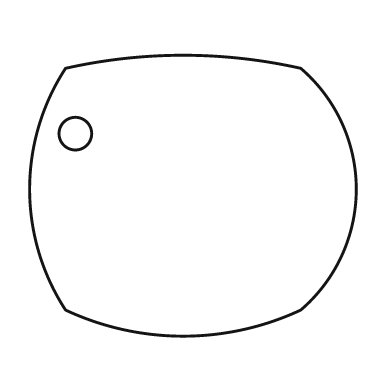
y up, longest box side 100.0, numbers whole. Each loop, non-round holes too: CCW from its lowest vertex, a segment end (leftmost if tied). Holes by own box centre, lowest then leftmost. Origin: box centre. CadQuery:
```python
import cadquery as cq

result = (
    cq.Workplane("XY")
    .moveTo(-39.0, -35.0)
    .threePointArc((-3.0, -43.0), (33.0, -35.0))
    .threePointArc((50.0, 2.0), (33.0, 39.0))
    .threePointArc((-3.0, 43.0), (-39.0, 39.0))
    .threePointArc((-50.0, 2.0), (-39.0, -35.0))
    .close()
    .moveTo(-36.0, 19.0)
    .circle(5.0)
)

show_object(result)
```